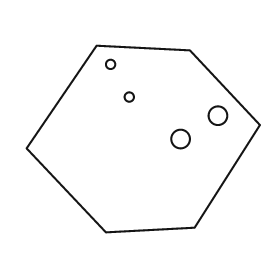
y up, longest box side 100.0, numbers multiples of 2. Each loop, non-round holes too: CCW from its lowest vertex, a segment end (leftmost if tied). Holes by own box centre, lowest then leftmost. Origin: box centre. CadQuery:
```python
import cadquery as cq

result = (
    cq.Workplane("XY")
    .moveTo(-16.0, -40.0)
    .lineTo(22.0, -38.0)
    .lineTo(50.0, 6.0)
    .lineTo(20.0, 38.0)
    .lineTo(-20.0, 40.0)
    .lineTo(-50.0, -4.0)
    .close()
    .moveTo(16.0, 0.0)
    .circle(4.0)
    .moveTo(32.0, 10.0)
    .circle(4.0)
    .moveTo(-6.0, 18.0)
    .circle(2.0)
    .moveTo(-14.0, 32.0)
    .circle(2.0)
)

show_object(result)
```